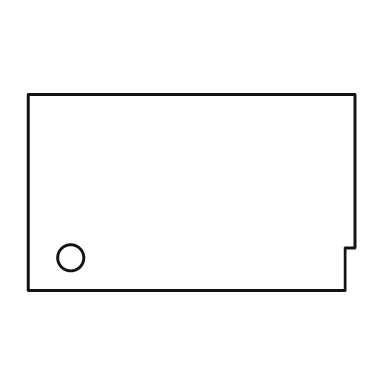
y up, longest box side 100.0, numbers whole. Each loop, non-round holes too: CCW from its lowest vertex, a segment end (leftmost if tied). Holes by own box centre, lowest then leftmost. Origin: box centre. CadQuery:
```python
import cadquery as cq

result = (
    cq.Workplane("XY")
    .moveTo(-50.0, -30.0)
    .lineTo(47.0, -30.0)
    .lineTo(47.0, -17.0)
    .lineTo(50.0, -17.0)
    .lineTo(50.0, 30.0)
    .lineTo(-50.0, 30.0)
    .close()
    .moveTo(-37.0, -20.0)
    .circle(4.0)
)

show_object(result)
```